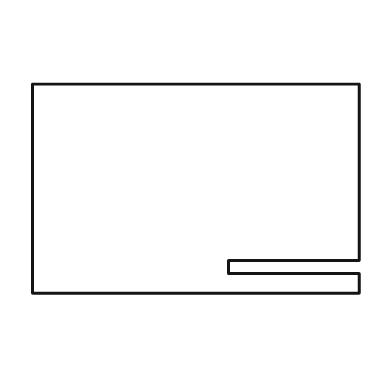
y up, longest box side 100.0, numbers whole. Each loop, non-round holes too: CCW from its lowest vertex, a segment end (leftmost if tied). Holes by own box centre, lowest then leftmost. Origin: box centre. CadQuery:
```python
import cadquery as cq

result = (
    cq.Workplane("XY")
    .moveTo(-50.0, -32.0)
    .lineTo(50.0, -32.0)
    .lineTo(50.0, -26.0)
    .lineTo(10.0, -26.0)
    .lineTo(10.0, -22.0)
    .lineTo(50.0, -22.0)
    .lineTo(50.0, 32.0)
    .lineTo(-50.0, 32.0)
    .close()
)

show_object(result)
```